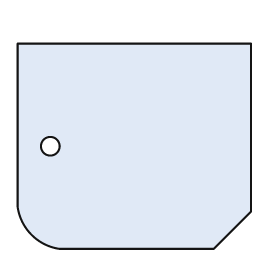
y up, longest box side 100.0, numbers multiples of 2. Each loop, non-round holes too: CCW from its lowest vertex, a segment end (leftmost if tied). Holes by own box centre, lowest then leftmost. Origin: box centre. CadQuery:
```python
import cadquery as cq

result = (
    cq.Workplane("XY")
    .moveTo(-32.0, -44.0)
    .lineTo(34.0, -44.0)
    .lineTo(50.0, -28.0)
    .lineTo(50.0, 44.0)
    .lineTo(-50.0, 44.0)
    .lineTo(-50.0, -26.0)
    .threePointArc((-44.0, -38.0), (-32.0, -44.0))
    .close()
    .moveTo(-36.0, 0.0)
    .circle(4.0)
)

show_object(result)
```